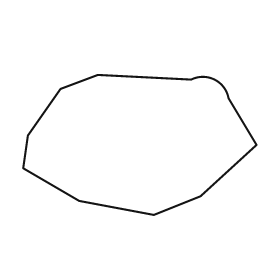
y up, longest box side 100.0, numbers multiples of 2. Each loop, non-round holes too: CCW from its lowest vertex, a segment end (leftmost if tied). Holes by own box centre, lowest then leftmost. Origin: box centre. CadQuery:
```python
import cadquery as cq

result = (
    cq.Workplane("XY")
    .moveTo(6.0, -30.0)
    .lineTo(26.0, -22.0)
    .lineTo(50.0, 0.0)
    .lineTo(38.0, 20.0)
    .threePointArc((32.0, 28.0), (22.0, 28.0))
    .lineTo(-18.0, 30.0)
    .lineTo(-34.0, 24.0)
    .lineTo(-48.0, 4.0)
    .lineTo(-50.0, -10.0)
    .lineTo(-26.0, -24.0)
    .close()
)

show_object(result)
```